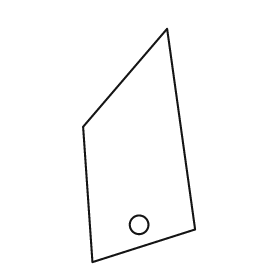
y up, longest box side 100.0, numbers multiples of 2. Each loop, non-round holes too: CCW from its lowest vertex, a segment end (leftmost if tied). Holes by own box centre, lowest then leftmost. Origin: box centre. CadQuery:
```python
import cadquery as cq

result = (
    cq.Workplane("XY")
    .moveTo(-20.0, -50.0)
    .lineTo(24.0, -36.0)
    .lineTo(12.0, 50.0)
    .lineTo(-24.0, 8.0)
    .close()
    .moveTo(0.0, -34.0)
    .circle(4.0)
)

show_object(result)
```